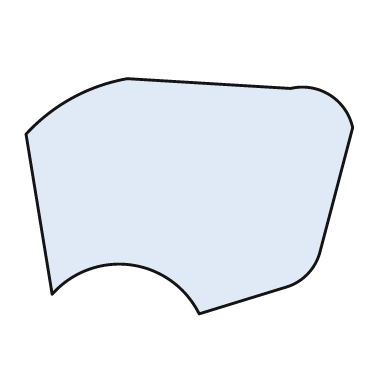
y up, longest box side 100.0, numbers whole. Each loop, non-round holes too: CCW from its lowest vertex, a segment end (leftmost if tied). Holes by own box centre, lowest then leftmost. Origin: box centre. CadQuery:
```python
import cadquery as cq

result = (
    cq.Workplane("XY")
    .moveTo(3.0, -36.0)
    .lineTo(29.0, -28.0)
    .threePointArc((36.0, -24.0), (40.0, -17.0))
    .lineTo(50.0, 21.0)
    .threePointArc((43.0, 31.0), (31.0, 33.0))
    .lineTo(-19.0, 36.0)
    .threePointArc((-36.0, 30.0), (-50.0, 19.0))
    .lineTo(-42.0, -30.0)
    .threePointArc((-18.0, -21.0), (3.0, -36.0))
    .close()
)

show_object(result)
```